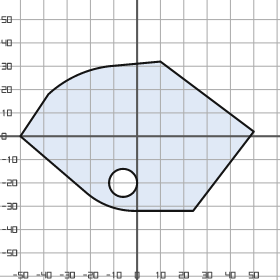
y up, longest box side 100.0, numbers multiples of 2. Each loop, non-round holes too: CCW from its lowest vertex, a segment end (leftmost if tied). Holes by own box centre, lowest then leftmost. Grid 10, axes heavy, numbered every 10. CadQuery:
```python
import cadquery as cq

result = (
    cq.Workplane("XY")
    .moveTo(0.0, -32.0)
    .lineTo(24.0, -32.0)
    .lineTo(50.0, 2.0)
    .lineTo(10.0, 32.0)
    .lineTo(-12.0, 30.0)
    .threePointArc((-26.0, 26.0), (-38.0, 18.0))
    .lineTo(-50.0, 0.0)
    .lineTo(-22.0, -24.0)
    .threePointArc((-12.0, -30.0), (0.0, -32.0))
    .close()
    .moveTo(-6.0, -20.0)
    .circle(6.0)
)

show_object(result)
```